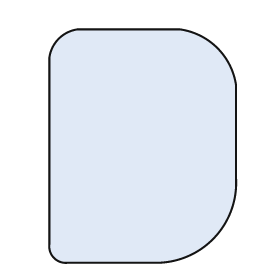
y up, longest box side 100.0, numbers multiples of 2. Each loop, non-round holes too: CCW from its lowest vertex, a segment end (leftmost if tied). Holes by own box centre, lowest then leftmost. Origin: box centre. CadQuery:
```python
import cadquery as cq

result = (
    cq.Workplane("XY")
    .moveTo(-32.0, -50.0)
    .lineTo(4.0, -50.0)
    .threePointArc((30.0, -40.0), (40.0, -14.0))
    .lineTo(40.0, 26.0)
    .threePointArc((32.0, 42.0), (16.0, 50.0))
    .lineTo(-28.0, 50.0)
    .threePointArc((-36.0, 46.0), (-40.0, 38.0))
    .lineTo(-40.0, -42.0)
    .threePointArc((-38.0, -48.0), (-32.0, -50.0))
    .close()
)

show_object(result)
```